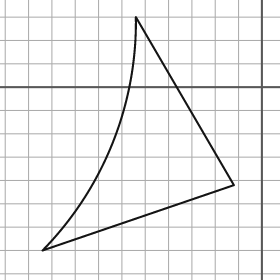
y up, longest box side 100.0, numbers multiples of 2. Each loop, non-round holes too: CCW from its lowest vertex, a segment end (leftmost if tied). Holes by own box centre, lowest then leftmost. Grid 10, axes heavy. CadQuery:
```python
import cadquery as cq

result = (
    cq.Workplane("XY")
    .moveTo(-94.0, -70.0)
    .lineTo(-12.0, -42.0)
    .lineTo(-54.0, 30.0)
    .threePointArc((-64.0, -24.0), (-94.0, -70.0))
    .close()
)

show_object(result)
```